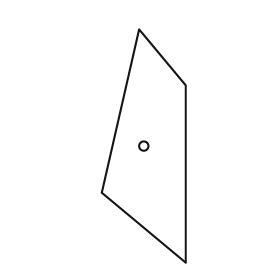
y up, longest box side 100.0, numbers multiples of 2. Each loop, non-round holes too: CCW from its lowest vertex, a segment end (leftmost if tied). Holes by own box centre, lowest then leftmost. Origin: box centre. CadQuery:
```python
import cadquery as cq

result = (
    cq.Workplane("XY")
    .moveTo(18.0, -50.0)
    .lineTo(18.0, 26.0)
    .lineTo(-2.0, 50.0)
    .lineTo(-18.0, -20.0)
    .close()
    .moveTo(0.0, 0.0)
    .circle(2.0)
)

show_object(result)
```